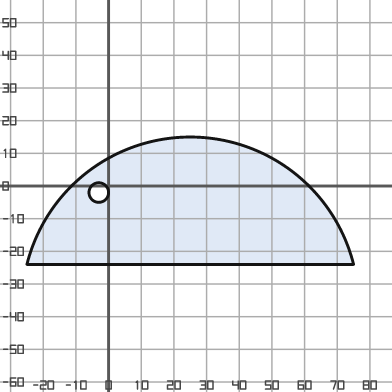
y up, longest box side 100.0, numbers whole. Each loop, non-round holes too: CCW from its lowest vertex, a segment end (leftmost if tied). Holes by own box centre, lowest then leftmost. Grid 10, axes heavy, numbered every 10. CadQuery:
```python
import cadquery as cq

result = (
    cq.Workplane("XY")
    .moveTo(-25.0, -24.0)
    .lineTo(75.0, -24.0)
    .threePointArc((25.0, 15.0), (-25.0, -24.0))
    .close()
    .moveTo(-3.0, -2.0)
    .circle(3.0)
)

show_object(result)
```